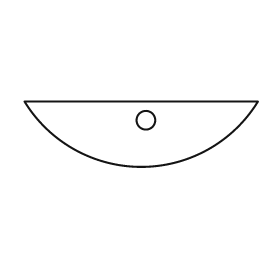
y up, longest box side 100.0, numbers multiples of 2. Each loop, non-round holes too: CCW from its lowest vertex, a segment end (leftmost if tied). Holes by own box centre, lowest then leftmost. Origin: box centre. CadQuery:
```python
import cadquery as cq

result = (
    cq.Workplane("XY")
    .moveTo(-50.0, 14.0)
    .threePointArc((0.0, -14.0), (50.0, 14.0))
    .close()
    .moveTo(2.0, 6.0)
    .circle(4.0)
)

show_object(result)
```